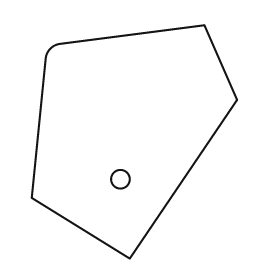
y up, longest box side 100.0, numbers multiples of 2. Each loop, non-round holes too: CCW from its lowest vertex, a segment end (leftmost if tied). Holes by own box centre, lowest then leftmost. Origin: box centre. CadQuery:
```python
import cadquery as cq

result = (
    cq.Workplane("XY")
    .moveTo(-2.0, -50.0)
    .lineTo(44.0, 18.0)
    .lineTo(30.0, 50.0)
    .lineTo(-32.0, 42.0)
    .threePointArc((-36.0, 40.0), (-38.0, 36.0))
    .lineTo(-44.0, -24.0)
    .close()
    .moveTo(-6.0, -16.0)
    .circle(4.0)
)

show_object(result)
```